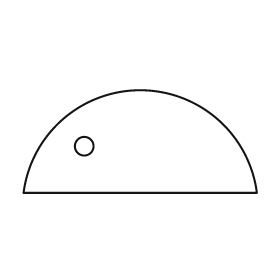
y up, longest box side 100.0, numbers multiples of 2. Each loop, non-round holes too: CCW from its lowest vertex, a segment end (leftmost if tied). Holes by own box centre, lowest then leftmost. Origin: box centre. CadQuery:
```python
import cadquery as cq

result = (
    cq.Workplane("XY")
    .moveTo(-50.0, -22.0)
    .lineTo(50.0, -22.0)
    .threePointArc((0.0, 22.0), (-50.0, -22.0))
    .close()
    .moveTo(-24.0, -2.0)
    .circle(4.0)
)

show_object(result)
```